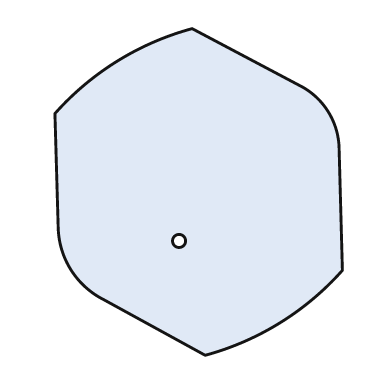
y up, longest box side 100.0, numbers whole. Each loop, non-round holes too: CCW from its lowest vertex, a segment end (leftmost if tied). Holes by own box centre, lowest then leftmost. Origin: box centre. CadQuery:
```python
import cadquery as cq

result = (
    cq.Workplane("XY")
    .moveTo(2.0, -50.0)
    .threePointArc((25.0, -40.0), (44.0, -24.0))
    .lineTo(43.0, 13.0)
    .threePointArc((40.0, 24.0), (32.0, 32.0))
    .lineTo(-2.0, 50.0)
    .threePointArc((-25.0, 40.0), (-44.0, 24.0))
    .lineTo(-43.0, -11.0)
    .threePointArc((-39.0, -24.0), (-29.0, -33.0))
    .close()
    .moveTo(-6.0, -15.0)
    .circle(2.0)
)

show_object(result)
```